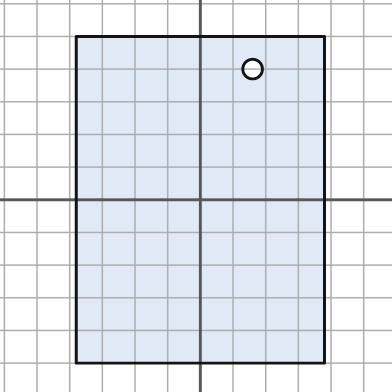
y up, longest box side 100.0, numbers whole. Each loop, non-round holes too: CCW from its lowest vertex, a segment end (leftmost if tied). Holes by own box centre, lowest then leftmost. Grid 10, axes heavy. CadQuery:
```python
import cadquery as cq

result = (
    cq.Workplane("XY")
    .moveTo(-38.0, -50.0)
    .lineTo(38.0, -50.0)
    .lineTo(38.0, 50.0)
    .lineTo(-38.0, 50.0)
    .close()
    .moveTo(16.0, 40.0)
    .circle(3.0)
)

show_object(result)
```